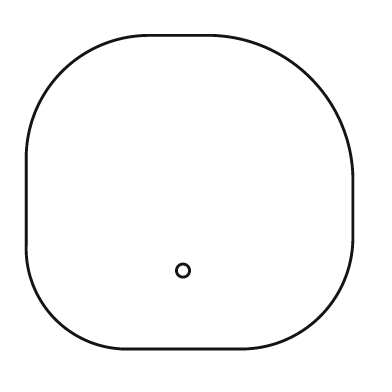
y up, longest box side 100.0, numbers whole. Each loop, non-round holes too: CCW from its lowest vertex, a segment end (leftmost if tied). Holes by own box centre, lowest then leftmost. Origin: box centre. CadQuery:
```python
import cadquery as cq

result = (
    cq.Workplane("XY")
    .moveTo(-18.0, -48.0)
    .lineTo(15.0, -48.0)
    .threePointArc((40.0, -38.0), (50.0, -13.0))
    .lineTo(50.0, 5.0)
    .threePointArc((37.0, 35.0), (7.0, 48.0))
    .lineTo(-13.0, 48.0)
    .threePointArc((-39.0, 37.0), (-50.0, 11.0))
    .lineTo(-50.0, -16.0)
    .threePointArc((-41.0, -39.0), (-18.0, -48.0))
    .close()
    .moveTo(-2.0, -24.0)
    .circle(2.0)
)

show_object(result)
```